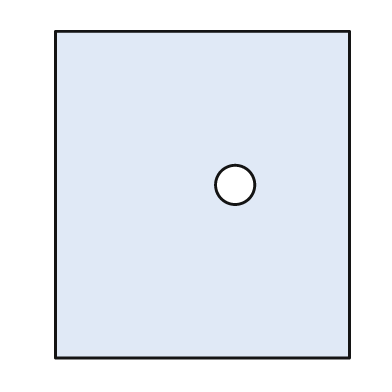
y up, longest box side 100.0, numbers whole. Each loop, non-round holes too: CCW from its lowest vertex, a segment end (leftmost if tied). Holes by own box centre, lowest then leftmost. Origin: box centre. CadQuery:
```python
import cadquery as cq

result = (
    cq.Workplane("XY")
    .moveTo(-45.0, -50.0)
    .lineTo(45.0, -50.0)
    .lineTo(45.0, 50.0)
    .lineTo(-45.0, 50.0)
    .close()
    .moveTo(10.0, 3.0)
    .circle(6.0)
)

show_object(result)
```